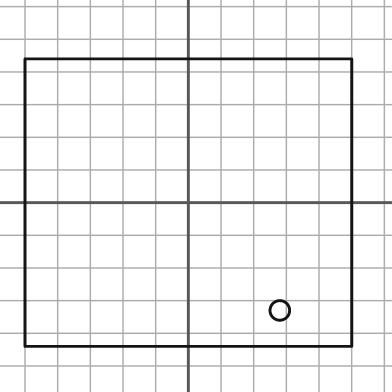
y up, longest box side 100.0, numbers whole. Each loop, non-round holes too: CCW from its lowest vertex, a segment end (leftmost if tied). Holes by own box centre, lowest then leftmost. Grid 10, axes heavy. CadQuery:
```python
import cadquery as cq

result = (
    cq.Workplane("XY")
    .moveTo(-50.0, -44.0)
    .lineTo(50.0, -44.0)
    .lineTo(50.0, 44.0)
    .lineTo(-50.0, 44.0)
    .close()
    .moveTo(28.0, -33.0)
    .circle(3.0)
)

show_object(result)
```